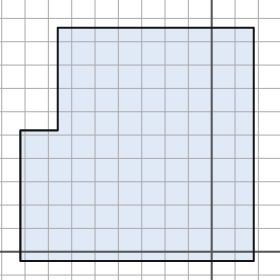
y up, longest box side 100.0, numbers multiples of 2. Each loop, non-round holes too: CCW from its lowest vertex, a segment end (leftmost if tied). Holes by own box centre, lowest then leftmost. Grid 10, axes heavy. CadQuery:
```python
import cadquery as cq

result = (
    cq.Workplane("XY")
    .moveTo(-82.0, -4.0)
    .lineTo(18.0, -4.0)
    .lineTo(18.0, 96.0)
    .lineTo(-66.0, 96.0)
    .lineTo(-66.0, 52.0)
    .lineTo(-82.0, 52.0)
    .close()
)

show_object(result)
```